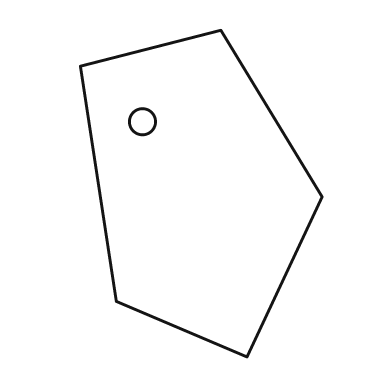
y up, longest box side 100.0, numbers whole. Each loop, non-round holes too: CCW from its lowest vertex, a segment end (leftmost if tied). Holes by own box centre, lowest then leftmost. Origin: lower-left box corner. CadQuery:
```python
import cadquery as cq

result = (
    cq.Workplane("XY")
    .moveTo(51.0, 0.0)
    .lineTo(74.0, 49.0)
    .lineTo(43.0, 100.0)
    .lineTo(0.0, 89.0)
    .lineTo(11.0, 17.0)
    .close()
    .moveTo(19.0, 72.0)
    .circle(4.0)
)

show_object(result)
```